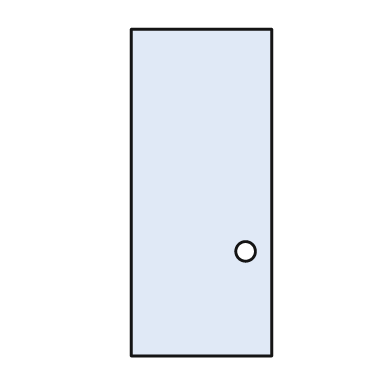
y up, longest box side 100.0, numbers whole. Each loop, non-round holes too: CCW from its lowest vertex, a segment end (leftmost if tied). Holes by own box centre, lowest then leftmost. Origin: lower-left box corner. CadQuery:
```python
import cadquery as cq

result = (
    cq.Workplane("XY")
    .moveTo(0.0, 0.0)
    .lineTo(43.0, 0.0)
    .lineTo(43.0, 100.0)
    .lineTo(0.0, 100.0)
    .close()
    .moveTo(35.0, 32.0)
    .circle(3.0)
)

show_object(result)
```